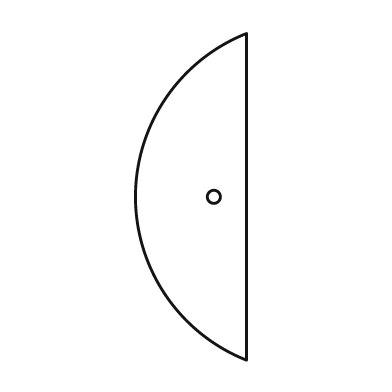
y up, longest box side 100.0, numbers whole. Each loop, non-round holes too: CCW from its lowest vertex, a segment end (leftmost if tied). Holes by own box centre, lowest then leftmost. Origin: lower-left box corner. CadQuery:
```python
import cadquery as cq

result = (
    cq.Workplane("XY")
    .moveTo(34.0, 0.0)
    .lineTo(34.0, 100.0)
    .threePointArc((0.0, 50.0), (34.0, 0.0))
    .close()
    .moveTo(24.0, 50.0)
    .circle(2.0)
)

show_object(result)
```